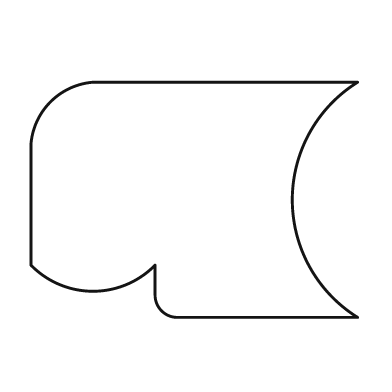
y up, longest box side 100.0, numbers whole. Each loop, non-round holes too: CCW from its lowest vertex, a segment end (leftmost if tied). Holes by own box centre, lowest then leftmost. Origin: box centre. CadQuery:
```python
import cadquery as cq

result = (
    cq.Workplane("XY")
    .moveTo(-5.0, -36.0)
    .lineTo(50.0, -36.0)
    .threePointArc((30.0, 0.0), (50.0, 36.0))
    .lineTo(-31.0, 36.0)
    .threePointArc((-44.0, 30.0), (-50.0, 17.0))
    .lineTo(-50.0, -20.0)
    .threePointArc((-31.0, -28.0), (-12.0, -20.0))
    .lineTo(-12.0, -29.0)
    .threePointArc((-10.0, -34.0), (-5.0, -36.0))
    .close()
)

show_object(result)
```